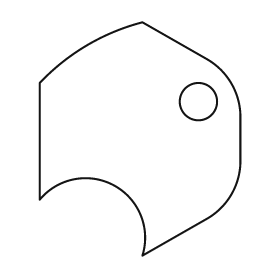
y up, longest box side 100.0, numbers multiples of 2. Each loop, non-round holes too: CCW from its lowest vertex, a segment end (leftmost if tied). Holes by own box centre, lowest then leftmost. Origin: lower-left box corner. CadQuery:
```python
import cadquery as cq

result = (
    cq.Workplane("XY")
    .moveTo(44.0, 0.0)
    .lineTo(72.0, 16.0)
    .threePointArc((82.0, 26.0), (86.0, 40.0))
    .lineTo(86.0, 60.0)
    .threePointArc((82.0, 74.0), (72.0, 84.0))
    .lineTo(44.0, 100.0)
    .threePointArc((20.0, 90.0), (0.0, 74.0))
    .lineTo(0.0, 24.0)
    .threePointArc((32.0, 30.0), (44.0, 0.0))
    .close()
    .moveTo(68.0, 66.0)
    .circle(8.0)
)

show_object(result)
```